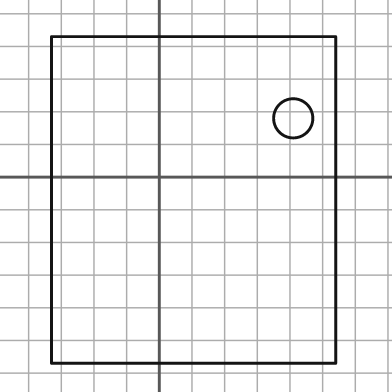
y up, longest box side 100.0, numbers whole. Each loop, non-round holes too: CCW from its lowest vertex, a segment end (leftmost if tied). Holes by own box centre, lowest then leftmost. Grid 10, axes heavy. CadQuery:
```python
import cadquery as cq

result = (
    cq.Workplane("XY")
    .moveTo(-33.0, -57.0)
    .lineTo(54.0, -57.0)
    .lineTo(54.0, 43.0)
    .lineTo(-33.0, 43.0)
    .close()
    .moveTo(41.0, 18.0)
    .circle(6.0)
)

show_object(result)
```